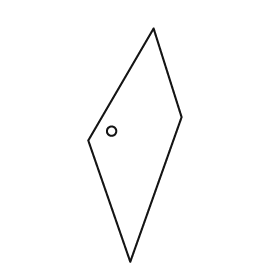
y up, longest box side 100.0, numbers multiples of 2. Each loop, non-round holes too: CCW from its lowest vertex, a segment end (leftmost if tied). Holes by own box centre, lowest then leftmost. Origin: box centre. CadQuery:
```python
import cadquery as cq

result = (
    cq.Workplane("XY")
    .moveTo(-2.0, -50.0)
    .lineTo(20.0, 12.0)
    .lineTo(8.0, 50.0)
    .lineTo(-20.0, 2.0)
    .close()
    .moveTo(-10.0, 6.0)
    .circle(2.0)
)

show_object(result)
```